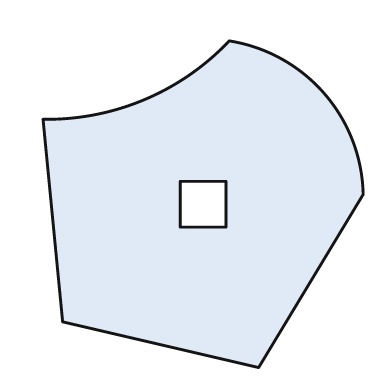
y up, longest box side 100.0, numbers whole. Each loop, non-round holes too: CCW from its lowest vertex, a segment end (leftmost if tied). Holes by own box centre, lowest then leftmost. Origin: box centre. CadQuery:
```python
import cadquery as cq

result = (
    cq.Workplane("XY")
    .moveTo(17.0, -50.0)
    .lineTo(49.0, 3.0)
    .threePointArc((37.0, 34.0), (8.0, 50.0))
    .threePointArc((-18.0, 32.0), (-49.0, 26.0))
    .lineTo(-43.0, -36.0)
    .close()
    .moveTo(-7.0, -7.0)
    .lineTo(7.0, -7.0)
    .lineTo(7.0, 7.0)
    .lineTo(-7.0, 7.0)
    .close()
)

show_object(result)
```